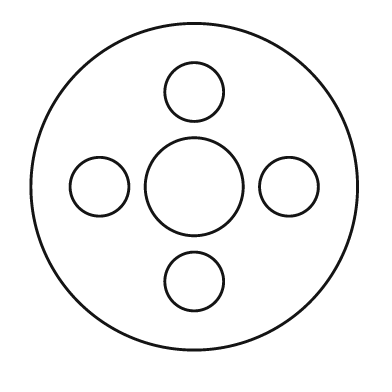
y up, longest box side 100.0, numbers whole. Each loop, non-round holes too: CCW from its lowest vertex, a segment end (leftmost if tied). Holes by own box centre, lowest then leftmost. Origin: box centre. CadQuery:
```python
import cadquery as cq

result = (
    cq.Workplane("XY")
    .moveTo(0.0, 0.0)
    .circle(50.0)
    .moveTo(0.0, -29.0)
    .circle(9.0)
    .moveTo(-29.0, 0.0)
    .circle(9.0)
    .moveTo(0.0, 0.0)
    .circle(15.0)
    .moveTo(29.0, 0.0)
    .circle(9.0)
    .moveTo(0.0, 29.0)
    .circle(9.0)
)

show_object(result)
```